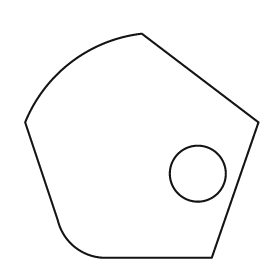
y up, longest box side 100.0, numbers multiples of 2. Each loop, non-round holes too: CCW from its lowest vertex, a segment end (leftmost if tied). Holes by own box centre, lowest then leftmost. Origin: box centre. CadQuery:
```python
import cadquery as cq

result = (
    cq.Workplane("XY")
    .moveTo(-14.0, -48.0)
    .lineTo(30.0, -48.0)
    .lineTo(50.0, 10.0)
    .lineTo(0.0, 48.0)
    .threePointArc((-30.0, 36.0), (-50.0, 10.0))
    .lineTo(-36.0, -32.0)
    .threePointArc((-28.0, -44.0), (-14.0, -48.0))
    .close()
    .moveTo(24.0, -12.0)
    .circle(12.0)
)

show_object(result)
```